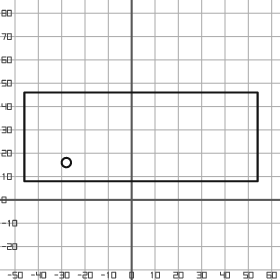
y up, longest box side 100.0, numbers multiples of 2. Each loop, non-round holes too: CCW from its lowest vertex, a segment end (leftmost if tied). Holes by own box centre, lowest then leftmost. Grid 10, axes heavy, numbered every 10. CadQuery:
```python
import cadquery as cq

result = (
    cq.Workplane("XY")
    .moveTo(-46.0, 8.0)
    .lineTo(54.0, 8.0)
    .lineTo(54.0, 46.0)
    .lineTo(-46.0, 46.0)
    .close()
    .moveTo(-28.0, 16.0)
    .circle(2.0)
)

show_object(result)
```